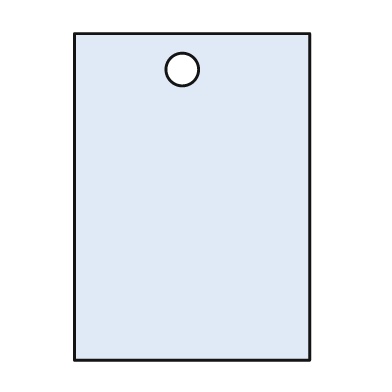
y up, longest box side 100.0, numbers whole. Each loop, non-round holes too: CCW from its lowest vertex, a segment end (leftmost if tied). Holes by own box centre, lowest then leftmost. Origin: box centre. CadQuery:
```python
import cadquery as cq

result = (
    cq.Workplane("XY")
    .moveTo(-36.0, -50.0)
    .lineTo(36.0, -50.0)
    .lineTo(36.0, 50.0)
    .lineTo(-36.0, 50.0)
    .close()
    .moveTo(-3.0, 39.0)
    .circle(5.0)
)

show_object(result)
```